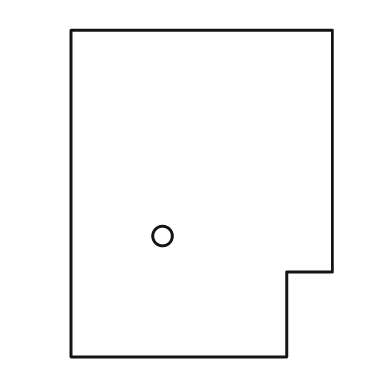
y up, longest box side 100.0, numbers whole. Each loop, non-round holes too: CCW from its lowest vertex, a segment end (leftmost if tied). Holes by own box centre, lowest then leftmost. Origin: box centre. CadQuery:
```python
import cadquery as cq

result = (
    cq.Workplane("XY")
    .moveTo(-40.0, -50.0)
    .lineTo(26.0, -50.0)
    .lineTo(26.0, -24.0)
    .lineTo(40.0, -24.0)
    .lineTo(40.0, 50.0)
    .lineTo(-40.0, 50.0)
    .close()
    .moveTo(-12.0, -13.0)
    .circle(3.0)
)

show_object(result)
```